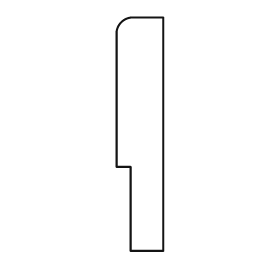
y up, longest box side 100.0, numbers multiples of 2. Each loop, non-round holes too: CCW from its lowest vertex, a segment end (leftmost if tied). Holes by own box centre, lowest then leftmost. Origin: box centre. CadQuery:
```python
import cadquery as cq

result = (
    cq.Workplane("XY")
    .moveTo(-4.0, -50.0)
    .lineTo(10.0, -50.0)
    .lineTo(10.0, 50.0)
    .lineTo(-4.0, 50.0)
    .threePointArc((-8.0, 48.0), (-10.0, 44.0))
    .lineTo(-10.0, -14.0)
    .lineTo(-4.0, -14.0)
    .close()
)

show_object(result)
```